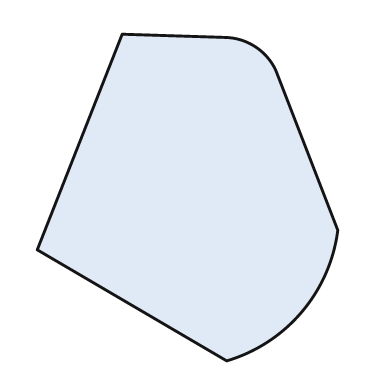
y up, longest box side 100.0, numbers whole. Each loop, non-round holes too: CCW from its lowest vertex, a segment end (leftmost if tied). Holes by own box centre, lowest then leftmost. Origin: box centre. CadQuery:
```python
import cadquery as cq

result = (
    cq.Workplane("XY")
    .moveTo(12.0, -50.0)
    .threePointArc((35.0, -35.0), (46.0, -10.0))
    .lineTo(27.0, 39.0)
    .threePointArc((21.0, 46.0), (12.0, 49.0))
    .lineTo(-20.0, 50.0)
    .lineTo(-46.0, -16.0)
    .close()
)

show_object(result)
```